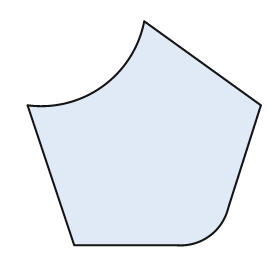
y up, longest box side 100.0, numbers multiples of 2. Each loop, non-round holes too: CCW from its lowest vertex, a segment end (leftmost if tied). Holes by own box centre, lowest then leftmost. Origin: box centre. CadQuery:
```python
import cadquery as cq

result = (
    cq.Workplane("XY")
    .moveTo(-30.0, -48.0)
    .lineTo(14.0, -48.0)
    .threePointArc((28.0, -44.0), (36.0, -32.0))
    .lineTo(50.0, 12.0)
    .lineTo(0.0, 48.0)
    .threePointArc((-18.0, 20.0), (-50.0, 12.0))
    .close()
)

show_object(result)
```